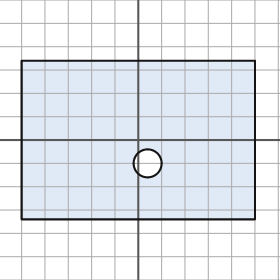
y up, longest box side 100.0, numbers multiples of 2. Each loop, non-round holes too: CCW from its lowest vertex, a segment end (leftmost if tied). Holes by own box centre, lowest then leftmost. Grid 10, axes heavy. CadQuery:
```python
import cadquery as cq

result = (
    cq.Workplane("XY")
    .moveTo(-50.0, -34.0)
    .lineTo(50.0, -34.0)
    .lineTo(50.0, 34.0)
    .lineTo(-50.0, 34.0)
    .close()
    .moveTo(4.0, -10.0)
    .circle(6.0)
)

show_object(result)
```